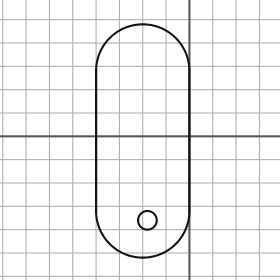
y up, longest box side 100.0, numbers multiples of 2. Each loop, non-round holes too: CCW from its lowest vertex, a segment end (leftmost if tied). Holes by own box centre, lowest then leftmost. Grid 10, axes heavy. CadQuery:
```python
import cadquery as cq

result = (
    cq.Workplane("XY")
    .moveTo(-40.0, -32.0)
    .threePointArc((-20.0, -52.0), (0.0, -32.0))
    .lineTo(0.0, 28.0)
    .threePointArc((-20.0, 48.0), (-40.0, 28.0))
    .close()
    .moveTo(-18.0, -36.0)
    .circle(4.0)
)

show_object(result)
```